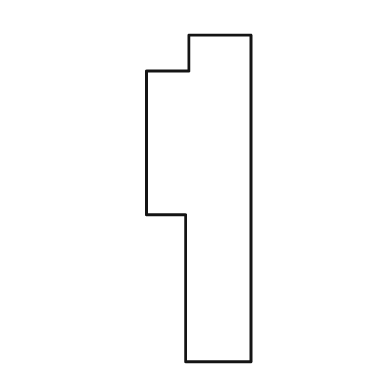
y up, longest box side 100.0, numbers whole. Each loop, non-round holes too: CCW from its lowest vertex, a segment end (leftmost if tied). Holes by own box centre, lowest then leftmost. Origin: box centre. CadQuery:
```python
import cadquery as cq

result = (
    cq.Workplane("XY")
    .moveTo(-4.0, -50.0)
    .lineTo(16.0, -50.0)
    .lineTo(16.0, 50.0)
    .lineTo(-3.0, 50.0)
    .lineTo(-3.0, 39.0)
    .lineTo(-16.0, 39.0)
    .lineTo(-16.0, -5.0)
    .lineTo(-4.0, -5.0)
    .close()
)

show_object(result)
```